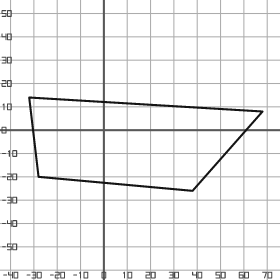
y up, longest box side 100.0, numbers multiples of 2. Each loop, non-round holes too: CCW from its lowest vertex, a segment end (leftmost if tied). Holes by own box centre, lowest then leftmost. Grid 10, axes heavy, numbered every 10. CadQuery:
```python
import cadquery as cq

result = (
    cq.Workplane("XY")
    .moveTo(38.0, -26.0)
    .lineTo(68.0, 8.0)
    .lineTo(-32.0, 14.0)
    .lineTo(-28.0, -20.0)
    .close()
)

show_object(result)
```